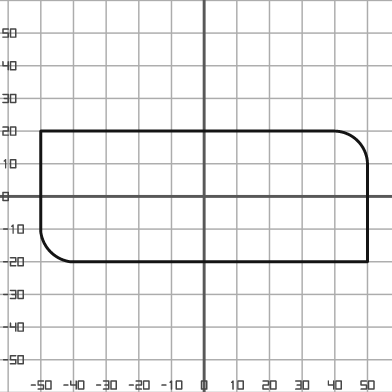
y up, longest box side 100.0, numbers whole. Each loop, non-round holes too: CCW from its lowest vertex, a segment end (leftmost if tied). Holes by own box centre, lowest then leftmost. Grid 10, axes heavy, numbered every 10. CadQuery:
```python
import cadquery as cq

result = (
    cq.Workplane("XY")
    .moveTo(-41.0, -20.0)
    .lineTo(50.0, -20.0)
    .lineTo(50.0, 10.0)
    .threePointArc((47.0, 17.0), (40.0, 20.0))
    .lineTo(-50.0, 20.0)
    .lineTo(-50.0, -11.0)
    .threePointArc((-47.0, -17.0), (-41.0, -20.0))
    .close()
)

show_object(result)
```